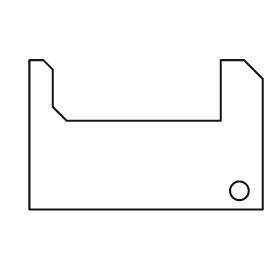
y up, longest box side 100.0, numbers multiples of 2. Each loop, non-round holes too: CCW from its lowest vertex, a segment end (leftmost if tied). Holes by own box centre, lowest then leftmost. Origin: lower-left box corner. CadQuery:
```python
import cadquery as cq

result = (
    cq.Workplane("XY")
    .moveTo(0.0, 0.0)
    .lineTo(100.0, 0.0)
    .lineTo(100.0, 56.0)
    .lineTo(92.0, 64.0)
    .lineTo(82.0, 64.0)
    .lineTo(82.0, 38.0)
    .lineTo(16.0, 38.0)
    .lineTo(10.0, 44.0)
    .lineTo(10.0, 60.0)
    .lineTo(6.0, 64.0)
    .lineTo(0.0, 64.0)
    .close()
    .moveTo(90.0, 8.0)
    .circle(4.0)
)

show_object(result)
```